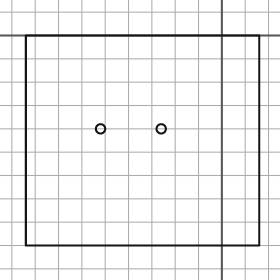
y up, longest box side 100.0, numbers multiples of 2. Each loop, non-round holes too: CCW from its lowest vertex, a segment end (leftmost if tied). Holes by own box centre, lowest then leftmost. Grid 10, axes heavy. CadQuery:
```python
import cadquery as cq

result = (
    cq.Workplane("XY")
    .moveTo(-84.0, -90.0)
    .lineTo(16.0, -90.0)
    .lineTo(16.0, 0.0)
    .lineTo(-84.0, 0.0)
    .close()
    .moveTo(-52.0, -40.0)
    .circle(2.0)
    .moveTo(-26.0, -40.0)
    .circle(2.0)
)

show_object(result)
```